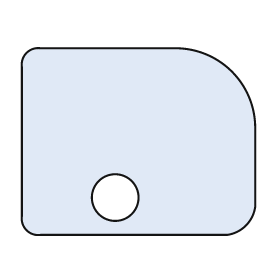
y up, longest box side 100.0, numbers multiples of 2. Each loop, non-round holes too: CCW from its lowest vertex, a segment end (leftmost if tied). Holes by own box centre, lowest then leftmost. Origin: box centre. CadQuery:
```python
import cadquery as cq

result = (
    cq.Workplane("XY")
    .moveTo(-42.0, -40.0)
    .lineTo(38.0, -40.0)
    .threePointArc((46.0, -36.0), (50.0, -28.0))
    .lineTo(50.0, 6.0)
    .threePointArc((40.0, 30.0), (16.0, 40.0))
    .lineTo(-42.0, 40.0)
    .threePointArc((-48.0, 38.0), (-50.0, 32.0))
    .lineTo(-50.0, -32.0)
    .threePointArc((-48.0, -38.0), (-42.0, -40.0))
    .close()
    .moveTo(-10.0, -24.0)
    .circle(10.0)
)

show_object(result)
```